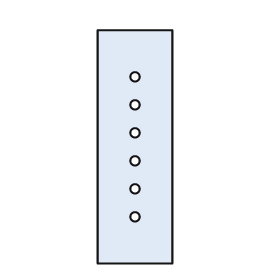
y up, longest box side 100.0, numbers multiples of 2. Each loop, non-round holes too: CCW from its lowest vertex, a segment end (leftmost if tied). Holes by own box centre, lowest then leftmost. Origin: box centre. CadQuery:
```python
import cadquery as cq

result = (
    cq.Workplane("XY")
    .moveTo(-16.0, -50.0)
    .lineTo(16.0, -50.0)
    .lineTo(16.0, 50.0)
    .lineTo(-16.0, 50.0)
    .close()
    .moveTo(0.0, -30.0)
    .circle(2.0)
    .moveTo(0.0, -18.0)
    .circle(2.0)
    .moveTo(0.0, -6.0)
    .circle(2.0)
    .moveTo(0.0, 6.0)
    .circle(2.0)
    .moveTo(0.0, 18.0)
    .circle(2.0)
    .moveTo(0.0, 30.0)
    .circle(2.0)
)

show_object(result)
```